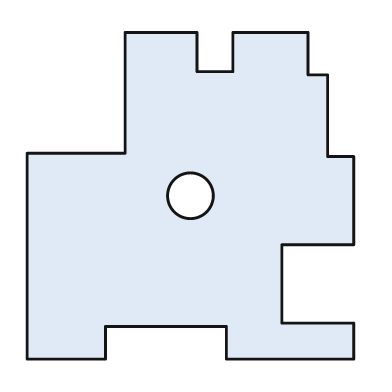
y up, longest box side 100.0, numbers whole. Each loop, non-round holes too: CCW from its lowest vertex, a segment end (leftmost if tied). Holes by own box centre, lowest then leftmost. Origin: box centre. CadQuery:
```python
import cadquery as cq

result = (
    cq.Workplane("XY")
    .moveTo(-50.0, -50.0)
    .lineTo(-26.0, -50.0)
    .lineTo(-26.0, -40.0)
    .lineTo(11.0, -40.0)
    .lineTo(11.0, -50.0)
    .lineTo(50.0, -50.0)
    .lineTo(50.0, -39.0)
    .lineTo(28.0, -39.0)
    .lineTo(28.0, -15.0)
    .lineTo(50.0, -15.0)
    .lineTo(50.0, 12.0)
    .lineTo(42.0, 12.0)
    .lineTo(42.0, 37.0)
    .lineTo(36.0, 37.0)
    .lineTo(36.0, 50.0)
    .lineTo(13.0, 50.0)
    .lineTo(13.0, 38.0)
    .lineTo(2.0, 38.0)
    .lineTo(2.0, 50.0)
    .lineTo(-20.0, 50.0)
    .lineTo(-20.0, 13.0)
    .lineTo(-50.0, 13.0)
    .close()
    .moveTo(0.0, 0.0)
    .circle(7.0)
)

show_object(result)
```